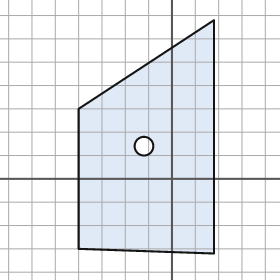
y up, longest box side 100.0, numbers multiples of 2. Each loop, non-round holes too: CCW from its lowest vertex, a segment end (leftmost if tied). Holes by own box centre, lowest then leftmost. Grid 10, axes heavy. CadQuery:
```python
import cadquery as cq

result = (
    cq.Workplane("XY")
    .moveTo(18.0, -32.0)
    .lineTo(18.0, 68.0)
    .lineTo(-40.0, 30.0)
    .lineTo(-40.0, -30.0)
    .close()
    .moveTo(-12.0, 14.0)
    .circle(4.0)
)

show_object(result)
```